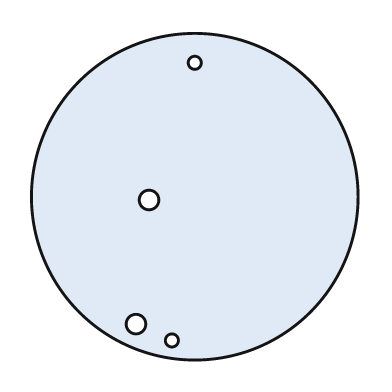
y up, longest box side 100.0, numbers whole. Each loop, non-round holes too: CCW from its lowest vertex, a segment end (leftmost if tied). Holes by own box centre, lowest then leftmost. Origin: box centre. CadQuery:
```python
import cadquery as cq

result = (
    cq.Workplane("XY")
    .moveTo(0.0, 0.0)
    .circle(50.0)
    .moveTo(-7.0, -44.0)
    .circle(2.0)
    .moveTo(-18.0, -39.0)
    .circle(3.0)
    .moveTo(-14.0, -1.0)
    .circle(3.0)
    .moveTo(0.0, 41.0)
    .circle(2.0)
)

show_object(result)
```